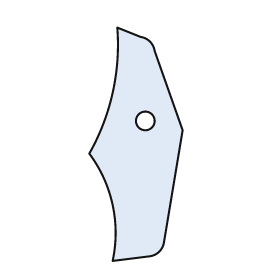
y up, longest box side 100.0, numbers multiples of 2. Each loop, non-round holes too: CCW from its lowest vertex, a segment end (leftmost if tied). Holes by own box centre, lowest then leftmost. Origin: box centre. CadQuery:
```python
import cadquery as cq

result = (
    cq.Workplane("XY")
    .moveTo(-10.0, -50.0)
    .lineTo(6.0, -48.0)
    .threePointArc((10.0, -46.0), (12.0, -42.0))
    .lineTo(20.0, 6.0)
    .lineTo(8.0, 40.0)
    .threePointArc((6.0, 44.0), (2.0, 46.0))
    .lineTo(-8.0, 50.0)
    .threePointArc((-10.0, 22.0), (-20.0, -4.0))
    .threePointArc((-10.0, -26.0), (-10.0, -50.0))
    .close()
    .moveTo(4.0, 10.0)
    .circle(4.0)
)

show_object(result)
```